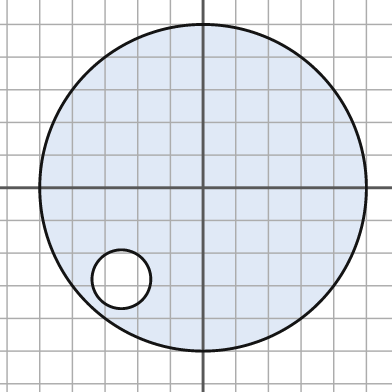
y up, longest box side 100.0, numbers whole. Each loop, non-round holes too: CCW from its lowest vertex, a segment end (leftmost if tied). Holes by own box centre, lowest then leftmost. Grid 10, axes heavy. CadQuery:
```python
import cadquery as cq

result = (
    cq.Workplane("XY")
    .moveTo(0.0, 0.0)
    .circle(50.0)
    .moveTo(-25.0, -28.0)
    .circle(9.0)
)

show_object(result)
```